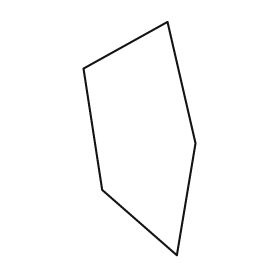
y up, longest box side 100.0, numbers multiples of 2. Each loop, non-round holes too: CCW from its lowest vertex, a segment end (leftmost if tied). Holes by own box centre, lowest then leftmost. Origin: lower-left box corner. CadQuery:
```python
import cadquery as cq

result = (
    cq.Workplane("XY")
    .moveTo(40.0, 0.0)
    .lineTo(48.0, 48.0)
    .lineTo(36.0, 100.0)
    .lineTo(0.0, 80.0)
    .lineTo(8.0, 28.0)
    .close()
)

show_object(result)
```